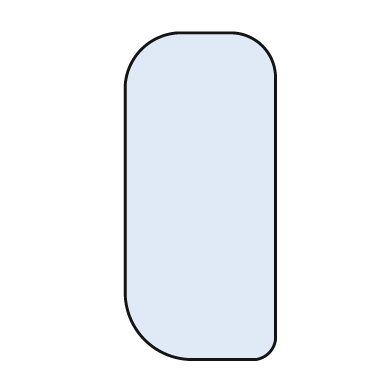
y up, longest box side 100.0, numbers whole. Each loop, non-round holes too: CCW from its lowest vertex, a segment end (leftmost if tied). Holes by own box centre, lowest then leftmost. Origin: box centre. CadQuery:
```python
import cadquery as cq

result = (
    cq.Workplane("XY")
    .moveTo(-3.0, -50.0)
    .lineTo(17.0, -50.0)
    .threePointArc((21.0, -48.0), (23.0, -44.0))
    .lineTo(23.0, 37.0)
    .threePointArc((19.0, 46.0), (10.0, 50.0))
    .lineTo(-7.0, 50.0)
    .threePointArc((-18.0, 45.0), (-23.0, 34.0))
    .lineTo(-23.0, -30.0)
    .threePointArc((-17.0, -44.0), (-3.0, -50.0))
    .close()
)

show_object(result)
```